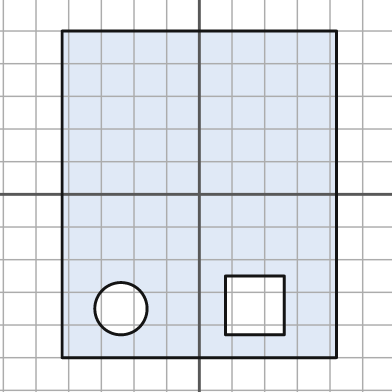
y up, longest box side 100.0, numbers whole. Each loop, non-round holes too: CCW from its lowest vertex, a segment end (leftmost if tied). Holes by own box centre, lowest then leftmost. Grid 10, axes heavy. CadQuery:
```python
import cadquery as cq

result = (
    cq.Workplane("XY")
    .moveTo(-42.0, -50.0)
    .lineTo(42.0, -50.0)
    .lineTo(42.0, 50.0)
    .lineTo(-42.0, 50.0)
    .close()
    .moveTo(-24.0, -35.0)
    .circle(8.0)
    .moveTo(8.0, -43.0)
    .lineTo(26.0, -43.0)
    .lineTo(26.0, -25.0)
    .lineTo(8.0, -25.0)
    .close()
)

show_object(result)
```